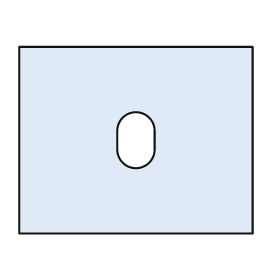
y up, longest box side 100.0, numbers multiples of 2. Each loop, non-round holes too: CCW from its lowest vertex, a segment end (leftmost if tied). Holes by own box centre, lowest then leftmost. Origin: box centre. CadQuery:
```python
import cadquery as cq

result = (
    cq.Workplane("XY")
    .moveTo(-50.0, -40.0)
    .lineTo(50.0, -40.0)
    .lineTo(50.0, 40.0)
    .lineTo(-50.0, 40.0)
    .close()
    .moveTo(-8.0, -4.0)
    .threePointArc((0.0, -12.0), (8.0, -4.0))
    .lineTo(8.0, 4.0)
    .threePointArc((0.0, 12.0), (-8.0, 4.0))
    .close()
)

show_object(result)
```